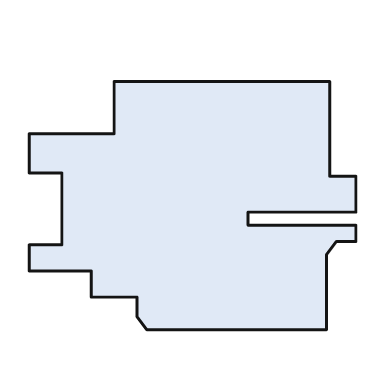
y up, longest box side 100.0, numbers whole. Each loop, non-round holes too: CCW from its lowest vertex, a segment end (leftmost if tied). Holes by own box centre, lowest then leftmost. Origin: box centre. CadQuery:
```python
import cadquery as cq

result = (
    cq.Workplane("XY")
    .moveTo(-14.0, -38.0)
    .lineTo(41.0, -38.0)
    .lineTo(41.0, -15.0)
    .lineTo(44.0, -11.0)
    .lineTo(50.0, -11.0)
    .lineTo(50.0, -6.0)
    .lineTo(17.0, -6.0)
    .lineTo(17.0, -2.0)
    .lineTo(50.0, -2.0)
    .lineTo(50.0, 9.0)
    .lineTo(42.0, 9.0)
    .lineTo(42.0, 38.0)
    .lineTo(-24.0, 38.0)
    .lineTo(-24.0, 22.0)
    .lineTo(-50.0, 22.0)
    .lineTo(-50.0, 10.0)
    .lineTo(-40.0, 10.0)
    .lineTo(-40.0, -12.0)
    .lineTo(-50.0, -12.0)
    .lineTo(-50.0, -20.0)
    .lineTo(-31.0, -20.0)
    .lineTo(-31.0, -28.0)
    .lineTo(-17.0, -28.0)
    .lineTo(-17.0, -34.0)
    .close()
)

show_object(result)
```